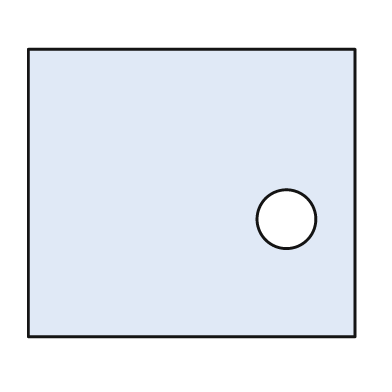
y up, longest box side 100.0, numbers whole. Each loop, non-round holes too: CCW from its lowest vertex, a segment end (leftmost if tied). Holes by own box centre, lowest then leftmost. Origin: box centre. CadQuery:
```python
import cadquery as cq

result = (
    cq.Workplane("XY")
    .moveTo(-50.0, -44.0)
    .lineTo(50.0, -44.0)
    .lineTo(50.0, 44.0)
    .lineTo(-50.0, 44.0)
    .close()
    .moveTo(29.0, -8.0)
    .circle(9.0)
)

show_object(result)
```